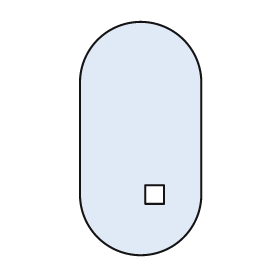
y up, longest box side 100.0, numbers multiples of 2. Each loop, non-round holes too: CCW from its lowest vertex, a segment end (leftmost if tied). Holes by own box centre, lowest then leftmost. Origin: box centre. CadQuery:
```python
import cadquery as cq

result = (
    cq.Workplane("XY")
    .moveTo(-26.0, -24.0)
    .threePointArc((0.0, -50.0), (26.0, -24.0))
    .lineTo(26.0, 24.0)
    .threePointArc((0.0, 50.0), (-26.0, 24.0))
    .close()
    .moveTo(2.0, -28.0)
    .lineTo(10.0, -28.0)
    .lineTo(10.0, -20.0)
    .lineTo(2.0, -20.0)
    .close()
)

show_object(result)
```